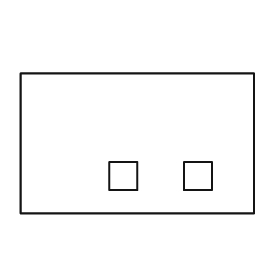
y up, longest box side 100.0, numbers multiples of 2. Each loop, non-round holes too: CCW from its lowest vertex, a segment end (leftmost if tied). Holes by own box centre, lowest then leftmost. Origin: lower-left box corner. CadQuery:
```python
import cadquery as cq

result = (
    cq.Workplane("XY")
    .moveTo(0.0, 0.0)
    .lineTo(100.0, 0.0)
    .lineTo(100.0, 60.0)
    .lineTo(0.0, 60.0)
    .close()
    .moveTo(38.0, 10.0)
    .lineTo(50.0, 10.0)
    .lineTo(50.0, 22.0)
    .lineTo(38.0, 22.0)
    .close()
    .moveTo(70.0, 10.0)
    .lineTo(82.0, 10.0)
    .lineTo(82.0, 22.0)
    .lineTo(70.0, 22.0)
    .close()
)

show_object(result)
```